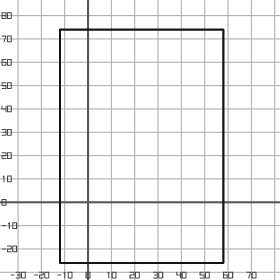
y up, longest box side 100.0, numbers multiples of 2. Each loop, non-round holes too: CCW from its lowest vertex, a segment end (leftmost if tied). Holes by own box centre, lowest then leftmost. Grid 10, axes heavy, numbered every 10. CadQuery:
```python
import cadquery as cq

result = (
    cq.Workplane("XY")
    .moveTo(-12.0, -26.0)
    .lineTo(58.0, -26.0)
    .lineTo(58.0, 74.0)
    .lineTo(-12.0, 74.0)
    .close()
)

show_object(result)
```